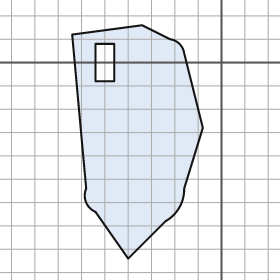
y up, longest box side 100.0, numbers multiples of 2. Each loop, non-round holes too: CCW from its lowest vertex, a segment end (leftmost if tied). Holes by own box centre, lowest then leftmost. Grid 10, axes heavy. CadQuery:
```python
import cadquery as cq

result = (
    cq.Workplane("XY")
    .moveTo(-40.0, -84.0)
    .lineTo(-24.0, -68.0)
    .threePointArc((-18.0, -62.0), (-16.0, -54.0))
    .lineTo(-8.0, -28.0)
    .lineTo(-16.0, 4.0)
    .threePointArc((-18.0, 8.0), (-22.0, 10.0))
    .lineTo(-34.0, 16.0)
    .lineTo(-64.0, 12.0)
    .lineTo(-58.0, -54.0)
    .threePointArc((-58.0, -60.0), (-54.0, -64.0))
    .close()
    .moveTo(-54.0, -8.0)
    .lineTo(-46.0, -8.0)
    .lineTo(-46.0, 8.0)
    .lineTo(-54.0, 8.0)
    .close()
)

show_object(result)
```